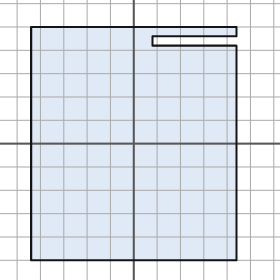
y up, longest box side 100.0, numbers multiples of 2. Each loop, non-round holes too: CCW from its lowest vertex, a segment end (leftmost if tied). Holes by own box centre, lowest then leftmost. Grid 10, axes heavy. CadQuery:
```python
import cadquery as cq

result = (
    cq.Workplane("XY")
    .moveTo(-44.0, -50.0)
    .lineTo(44.0, -50.0)
    .lineTo(44.0, 42.0)
    .lineTo(8.0, 42.0)
    .lineTo(8.0, 46.0)
    .lineTo(44.0, 46.0)
    .lineTo(44.0, 50.0)
    .lineTo(-44.0, 50.0)
    .close()
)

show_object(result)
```